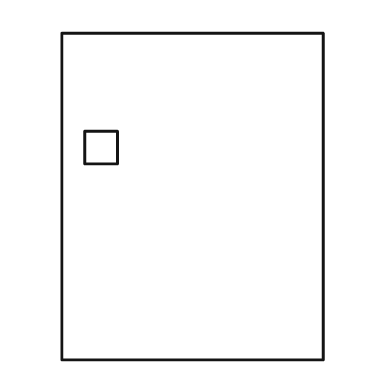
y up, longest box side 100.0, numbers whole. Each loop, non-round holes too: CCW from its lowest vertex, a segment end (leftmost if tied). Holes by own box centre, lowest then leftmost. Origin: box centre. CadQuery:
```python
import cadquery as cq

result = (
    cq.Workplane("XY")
    .moveTo(-40.0, -50.0)
    .lineTo(40.0, -50.0)
    .lineTo(40.0, 50.0)
    .lineTo(-40.0, 50.0)
    .close()
    .moveTo(-33.0, 10.0)
    .lineTo(-23.0, 10.0)
    .lineTo(-23.0, 20.0)
    .lineTo(-33.0, 20.0)
    .close()
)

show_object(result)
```